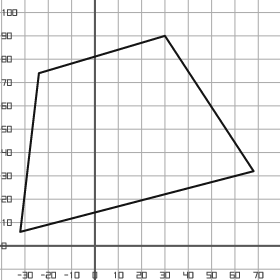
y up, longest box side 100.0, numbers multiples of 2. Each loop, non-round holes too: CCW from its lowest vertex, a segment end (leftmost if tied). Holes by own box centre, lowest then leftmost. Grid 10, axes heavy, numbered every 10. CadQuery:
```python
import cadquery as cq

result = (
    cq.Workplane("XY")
    .moveTo(-32.0, 6.0)
    .lineTo(68.0, 32.0)
    .lineTo(30.0, 90.0)
    .lineTo(-24.0, 74.0)
    .close()
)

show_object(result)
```